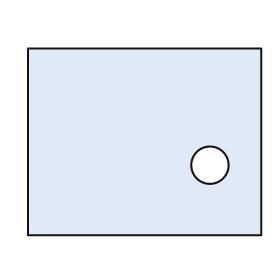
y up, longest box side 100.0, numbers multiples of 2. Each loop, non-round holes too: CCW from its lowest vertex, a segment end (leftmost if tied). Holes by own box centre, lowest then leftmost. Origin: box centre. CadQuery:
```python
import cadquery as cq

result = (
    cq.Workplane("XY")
    .moveTo(-50.0, -40.0)
    .lineTo(50.0, -40.0)
    .lineTo(50.0, 40.0)
    .lineTo(-50.0, 40.0)
    .close()
    .moveTo(28.0, -10.0)
    .circle(8.0)
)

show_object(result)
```